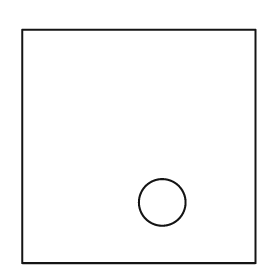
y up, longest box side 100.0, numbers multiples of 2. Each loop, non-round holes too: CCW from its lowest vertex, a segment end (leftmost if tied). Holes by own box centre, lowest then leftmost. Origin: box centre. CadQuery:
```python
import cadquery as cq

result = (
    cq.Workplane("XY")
    .moveTo(-50.0, -50.0)
    .lineTo(50.0, -50.0)
    .lineTo(50.0, 50.0)
    .lineTo(-50.0, 50.0)
    .close()
    .moveTo(10.0, -24.0)
    .circle(10.0)
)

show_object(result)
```